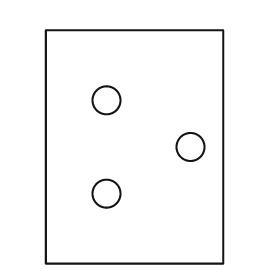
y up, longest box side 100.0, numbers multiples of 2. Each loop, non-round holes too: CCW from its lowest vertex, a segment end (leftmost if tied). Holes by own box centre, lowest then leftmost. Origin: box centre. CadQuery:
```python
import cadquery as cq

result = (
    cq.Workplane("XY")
    .moveTo(-38.0, -50.0)
    .lineTo(38.0, -50.0)
    .lineTo(38.0, 50.0)
    .lineTo(-38.0, 50.0)
    .close()
    .moveTo(-12.0, -20.0)
    .circle(6.0)
    .moveTo(24.0, 0.0)
    .circle(6.0)
    .moveTo(-12.0, 20.0)
    .circle(6.0)
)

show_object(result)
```